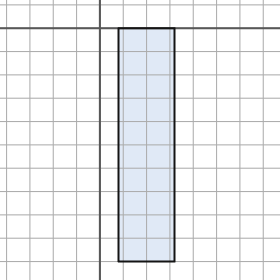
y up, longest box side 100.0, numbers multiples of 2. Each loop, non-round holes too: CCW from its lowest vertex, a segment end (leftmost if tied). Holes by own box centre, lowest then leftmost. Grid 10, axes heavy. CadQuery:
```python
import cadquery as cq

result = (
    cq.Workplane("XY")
    .moveTo(8.0, -100.0)
    .lineTo(32.0, -100.0)
    .lineTo(32.0, 0.0)
    .lineTo(8.0, 0.0)
    .close()
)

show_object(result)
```